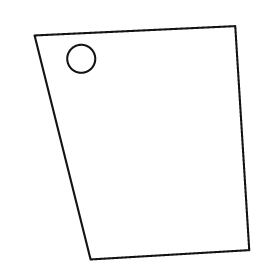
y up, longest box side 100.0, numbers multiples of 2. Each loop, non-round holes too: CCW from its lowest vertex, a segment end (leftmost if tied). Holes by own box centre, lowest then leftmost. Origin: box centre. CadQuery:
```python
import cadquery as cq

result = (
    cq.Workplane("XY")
    .moveTo(-22.0, -50.0)
    .lineTo(46.0, -46.0)
    .lineTo(40.0, 50.0)
    .lineTo(-46.0, 46.0)
    .close()
    .moveTo(-26.0, 36.0)
    .circle(6.0)
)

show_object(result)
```